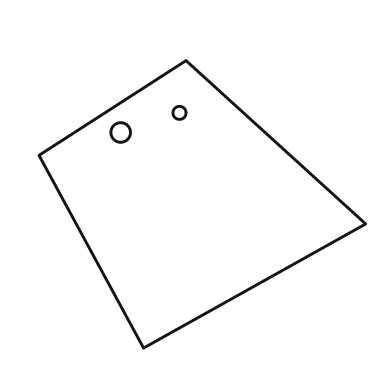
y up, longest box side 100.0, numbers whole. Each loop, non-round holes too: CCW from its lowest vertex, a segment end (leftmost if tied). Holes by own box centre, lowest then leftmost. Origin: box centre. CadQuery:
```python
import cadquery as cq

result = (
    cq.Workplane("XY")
    .moveTo(-18.0, -44.0)
    .lineTo(50.0, -6.0)
    .lineTo(-5.0, 44.0)
    .lineTo(-50.0, 15.0)
    .close()
    .moveTo(-25.0, 22.0)
    .circle(3.0)
    .moveTo(-7.0, 28.0)
    .circle(2.0)
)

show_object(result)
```